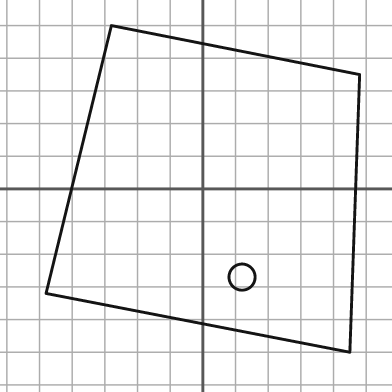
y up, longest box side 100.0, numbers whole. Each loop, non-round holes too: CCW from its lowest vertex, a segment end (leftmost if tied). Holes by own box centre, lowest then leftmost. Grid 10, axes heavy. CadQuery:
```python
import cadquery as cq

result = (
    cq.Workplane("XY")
    .moveTo(45.0, -50.0)
    .lineTo(48.0, 35.0)
    .lineTo(-28.0, 50.0)
    .lineTo(-48.0, -32.0)
    .close()
    .moveTo(12.0, -27.0)
    .circle(4.0)
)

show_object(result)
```